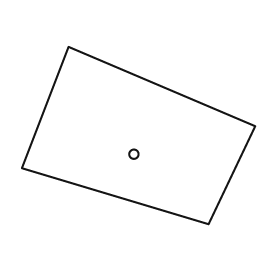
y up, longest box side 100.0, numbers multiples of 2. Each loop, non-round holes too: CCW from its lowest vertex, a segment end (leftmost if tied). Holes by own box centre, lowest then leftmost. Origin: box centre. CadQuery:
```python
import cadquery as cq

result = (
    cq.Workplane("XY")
    .moveTo(30.0, -38.0)
    .lineTo(50.0, 4.0)
    .lineTo(-30.0, 38.0)
    .lineTo(-50.0, -14.0)
    .close()
    .moveTo(-2.0, -8.0)
    .circle(2.0)
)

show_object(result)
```